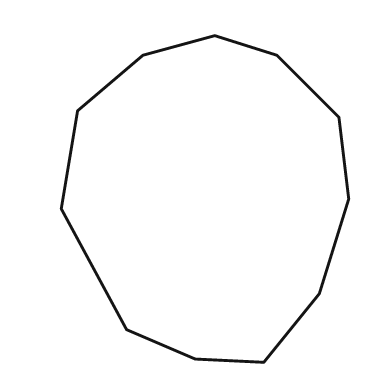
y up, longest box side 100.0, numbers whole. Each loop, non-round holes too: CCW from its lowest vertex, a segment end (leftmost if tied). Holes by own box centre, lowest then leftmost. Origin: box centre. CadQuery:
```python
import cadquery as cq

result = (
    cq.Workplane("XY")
    .moveTo(18.0, -50.0)
    .lineTo(35.0, -29.0)
    .lineTo(44.0, 0.0)
    .lineTo(41.0, 25.0)
    .lineTo(22.0, 44.0)
    .lineTo(3.0, 50.0)
    .lineTo(-19.0, 44.0)
    .lineTo(-39.0, 27.0)
    .lineTo(-44.0, -3.0)
    .lineTo(-24.0, -40.0)
    .lineTo(-3.0, -49.0)
    .close()
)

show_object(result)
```